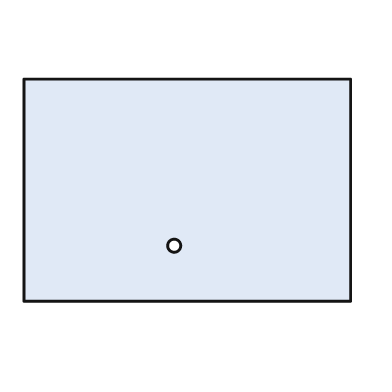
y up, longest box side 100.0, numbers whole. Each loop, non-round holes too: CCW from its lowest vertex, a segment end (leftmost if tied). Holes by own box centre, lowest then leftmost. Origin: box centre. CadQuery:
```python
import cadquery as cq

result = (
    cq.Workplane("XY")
    .moveTo(-50.0, -34.0)
    .lineTo(50.0, -34.0)
    .lineTo(50.0, 34.0)
    .lineTo(-50.0, 34.0)
    .close()
    .moveTo(-4.0, -17.0)
    .circle(2.0)
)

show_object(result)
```